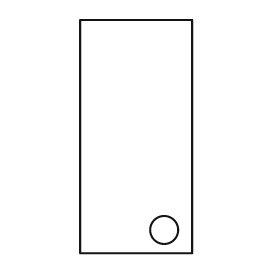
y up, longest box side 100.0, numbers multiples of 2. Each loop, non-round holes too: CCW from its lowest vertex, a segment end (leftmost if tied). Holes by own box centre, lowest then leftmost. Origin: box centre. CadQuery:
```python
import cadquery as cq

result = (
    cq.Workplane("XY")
    .moveTo(-24.0, -50.0)
    .lineTo(24.0, -50.0)
    .lineTo(24.0, 50.0)
    .lineTo(-24.0, 50.0)
    .close()
    .moveTo(12.0, -40.0)
    .circle(6.0)
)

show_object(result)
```